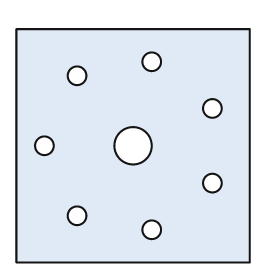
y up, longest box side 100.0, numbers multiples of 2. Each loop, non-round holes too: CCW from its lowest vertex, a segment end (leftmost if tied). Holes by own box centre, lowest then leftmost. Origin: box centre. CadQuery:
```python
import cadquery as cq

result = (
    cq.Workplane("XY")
    .moveTo(-50.0, -50.0)
    .lineTo(50.0, -50.0)
    .lineTo(50.0, 50.0)
    .lineTo(-50.0, 50.0)
    .close()
    .moveTo(8.0, -36.0)
    .circle(4.0)
    .moveTo(-24.0, -30.0)
    .circle(4.0)
    .moveTo(34.0, -16.0)
    .circle(4.0)
    .moveTo(-38.0, 0.0)
    .circle(4.0)
    .moveTo(0.0, 0.0)
    .circle(8.0)
    .moveTo(34.0, 16.0)
    .circle(4.0)
    .moveTo(-24.0, 30.0)
    .circle(4.0)
    .moveTo(8.0, 36.0)
    .circle(4.0)
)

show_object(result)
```